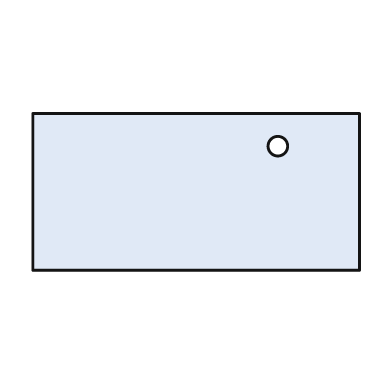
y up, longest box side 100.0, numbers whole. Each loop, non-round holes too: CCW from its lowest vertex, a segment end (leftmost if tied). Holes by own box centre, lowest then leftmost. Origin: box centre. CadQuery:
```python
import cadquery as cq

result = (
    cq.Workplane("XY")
    .moveTo(-50.0, -24.0)
    .lineTo(50.0, -24.0)
    .lineTo(50.0, 24.0)
    .lineTo(-50.0, 24.0)
    .close()
    .moveTo(25.0, 14.0)
    .circle(3.0)
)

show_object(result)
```